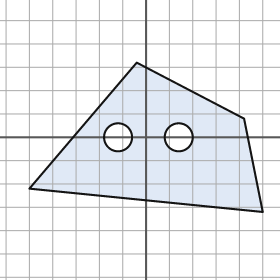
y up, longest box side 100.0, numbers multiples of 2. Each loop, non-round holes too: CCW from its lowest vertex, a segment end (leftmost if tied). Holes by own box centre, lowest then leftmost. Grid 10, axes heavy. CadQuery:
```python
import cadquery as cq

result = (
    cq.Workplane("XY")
    .moveTo(50.0, -32.0)
    .lineTo(42.0, 8.0)
    .lineTo(-4.0, 32.0)
    .lineTo(-50.0, -22.0)
    .close()
    .moveTo(-12.0, 0.0)
    .circle(6.0)
    .moveTo(14.0, 0.0)
    .circle(6.0)
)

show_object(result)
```